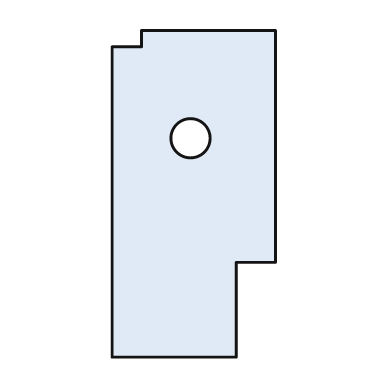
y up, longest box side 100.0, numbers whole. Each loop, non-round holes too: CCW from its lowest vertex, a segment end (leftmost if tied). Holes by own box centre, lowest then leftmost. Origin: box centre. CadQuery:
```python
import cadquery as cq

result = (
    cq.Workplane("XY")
    .moveTo(-25.0, -50.0)
    .lineTo(13.0, -50.0)
    .lineTo(13.0, -21.0)
    .lineTo(25.0, -21.0)
    .lineTo(25.0, 50.0)
    .lineTo(-16.0, 50.0)
    .lineTo(-16.0, 45.0)
    .lineTo(-25.0, 45.0)
    .close()
    .moveTo(-1.0, 17.0)
    .circle(6.0)
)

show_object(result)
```